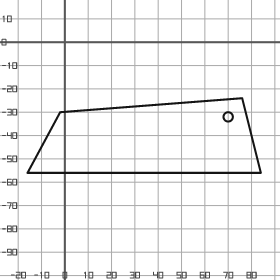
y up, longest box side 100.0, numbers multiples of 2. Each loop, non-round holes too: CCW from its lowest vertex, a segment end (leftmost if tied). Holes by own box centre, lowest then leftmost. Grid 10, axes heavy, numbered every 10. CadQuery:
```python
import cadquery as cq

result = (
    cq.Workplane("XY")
    .moveTo(-16.0, -56.0)
    .lineTo(84.0, -56.0)
    .lineTo(76.0, -24.0)
    .lineTo(-2.0, -30.0)
    .close()
    .moveTo(70.0, -32.0)
    .circle(2.0)
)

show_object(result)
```